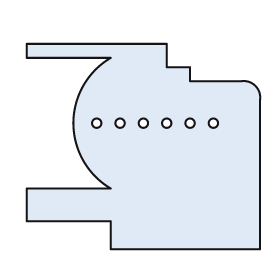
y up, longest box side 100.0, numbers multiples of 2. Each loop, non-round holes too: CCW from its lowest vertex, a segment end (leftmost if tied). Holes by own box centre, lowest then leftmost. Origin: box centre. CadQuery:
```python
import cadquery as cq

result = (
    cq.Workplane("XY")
    .moveTo(-14.0, -44.0)
    .lineTo(50.0, -44.0)
    .lineTo(50.0, 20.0)
    .threePointArc((48.0, 26.0), (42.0, 28.0))
    .lineTo(20.0, 28.0)
    .lineTo(20.0, 34.0)
    .lineTo(10.0, 34.0)
    .lineTo(10.0, 44.0)
    .lineTo(-50.0, 44.0)
    .lineTo(-50.0, 38.0)
    .lineTo(-14.0, 38.0)
    .threePointArc((-30.0, 10.0), (-14.0, -18.0))
    .lineTo(-50.0, -18.0)
    .lineTo(-50.0, -32.0)
    .lineTo(-14.0, -32.0)
    .close()
    .moveTo(-20.0, 10.0)
    .circle(2.0)
    .moveTo(-10.0, 10.0)
    .circle(2.0)
    .moveTo(0.0, 10.0)
    .circle(2.0)
    .moveTo(10.0, 10.0)
    .circle(2.0)
    .moveTo(20.0, 10.0)
    .circle(2.0)
    .moveTo(30.0, 10.0)
    .circle(2.0)
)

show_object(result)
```